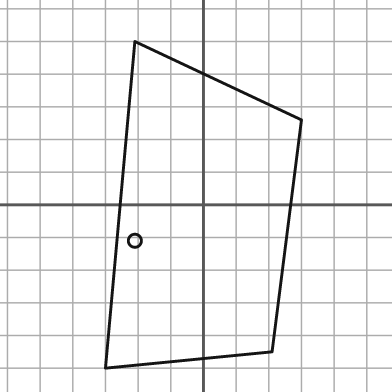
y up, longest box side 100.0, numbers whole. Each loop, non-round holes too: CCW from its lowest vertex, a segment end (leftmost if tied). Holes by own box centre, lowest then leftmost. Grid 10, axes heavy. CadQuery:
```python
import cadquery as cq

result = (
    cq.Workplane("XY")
    .moveTo(-30.0, -50.0)
    .lineTo(21.0, -45.0)
    .lineTo(30.0, 26.0)
    .lineTo(-21.0, 50.0)
    .close()
    .moveTo(-21.0, -11.0)
    .circle(2.0)
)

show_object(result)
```